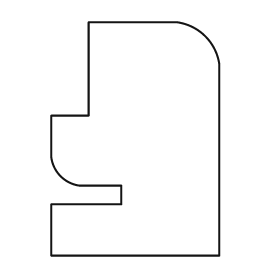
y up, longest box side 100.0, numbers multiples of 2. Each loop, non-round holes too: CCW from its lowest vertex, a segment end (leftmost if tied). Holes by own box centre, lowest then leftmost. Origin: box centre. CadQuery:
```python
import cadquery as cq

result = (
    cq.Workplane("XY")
    .moveTo(-36.0, -50.0)
    .lineTo(36.0, -50.0)
    .lineTo(36.0, 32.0)
    .threePointArc((30.0, 44.0), (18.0, 50.0))
    .lineTo(-20.0, 50.0)
    .lineTo(-20.0, 10.0)
    .lineTo(-36.0, 10.0)
    .lineTo(-36.0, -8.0)
    .threePointArc((-32.0, -16.0), (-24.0, -20.0))
    .lineTo(-6.0, -20.0)
    .lineTo(-6.0, -28.0)
    .lineTo(-36.0, -28.0)
    .close()
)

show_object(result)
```